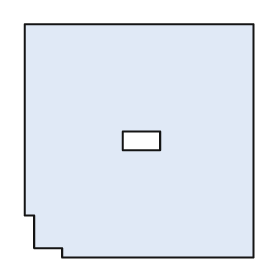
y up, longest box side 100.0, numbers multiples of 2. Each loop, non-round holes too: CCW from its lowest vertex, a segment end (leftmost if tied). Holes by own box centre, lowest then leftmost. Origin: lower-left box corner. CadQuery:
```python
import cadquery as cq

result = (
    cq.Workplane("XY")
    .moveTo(16.0, 0.0)
    .lineTo(98.0, 0.0)
    .lineTo(98.0, 100.0)
    .lineTo(0.0, 100.0)
    .lineTo(0.0, 18.0)
    .lineTo(4.0, 18.0)
    .lineTo(4.0, 4.0)
    .lineTo(16.0, 4.0)
    .close()
    .moveTo(42.0, 46.0)
    .lineTo(58.0, 46.0)
    .lineTo(58.0, 54.0)
    .lineTo(42.0, 54.0)
    .close()
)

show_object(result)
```